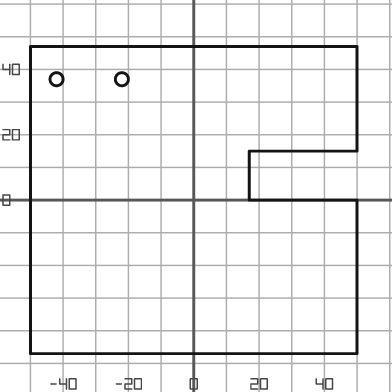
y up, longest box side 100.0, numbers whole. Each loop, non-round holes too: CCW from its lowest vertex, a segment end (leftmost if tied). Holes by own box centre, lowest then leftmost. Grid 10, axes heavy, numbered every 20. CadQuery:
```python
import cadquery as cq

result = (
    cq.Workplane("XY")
    .moveTo(-50.0, -47.0)
    .lineTo(50.0, -47.0)
    .lineTo(50.0, 0.0)
    .lineTo(17.0, 0.0)
    .lineTo(17.0, 15.0)
    .lineTo(50.0, 15.0)
    .lineTo(50.0, 47.0)
    .lineTo(-50.0, 47.0)
    .close()
    .moveTo(-42.0, 37.0)
    .circle(2.0)
    .moveTo(-22.0, 37.0)
    .circle(2.0)
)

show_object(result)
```